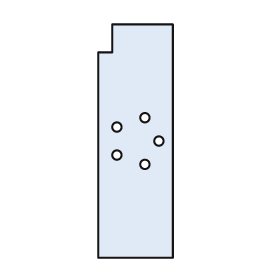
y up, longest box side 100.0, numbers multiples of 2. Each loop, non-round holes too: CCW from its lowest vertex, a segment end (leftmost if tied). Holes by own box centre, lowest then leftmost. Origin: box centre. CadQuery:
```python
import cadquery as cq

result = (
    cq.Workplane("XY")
    .moveTo(-16.0, -50.0)
    .lineTo(16.0, -50.0)
    .lineTo(16.0, 50.0)
    .lineTo(-10.0, 50.0)
    .lineTo(-10.0, 38.0)
    .lineTo(-16.0, 38.0)
    .close()
    .moveTo(4.0, -10.0)
    .circle(2.0)
    .moveTo(-8.0, -6.0)
    .circle(2.0)
    .moveTo(10.0, 0.0)
    .circle(2.0)
    .moveTo(-8.0, 6.0)
    .circle(2.0)
    .moveTo(4.0, 10.0)
    .circle(2.0)
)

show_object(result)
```